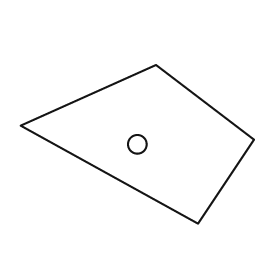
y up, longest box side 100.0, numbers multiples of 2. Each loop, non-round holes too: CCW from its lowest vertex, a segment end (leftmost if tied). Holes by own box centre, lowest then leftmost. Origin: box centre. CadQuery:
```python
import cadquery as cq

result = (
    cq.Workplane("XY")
    .moveTo(26.0, -34.0)
    .lineTo(50.0, 2.0)
    .lineTo(8.0, 34.0)
    .lineTo(-50.0, 8.0)
    .close()
    .moveTo(0.0, 0.0)
    .circle(4.0)
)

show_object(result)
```